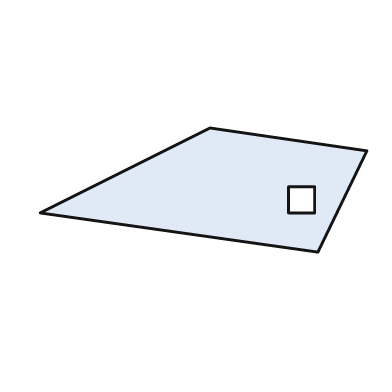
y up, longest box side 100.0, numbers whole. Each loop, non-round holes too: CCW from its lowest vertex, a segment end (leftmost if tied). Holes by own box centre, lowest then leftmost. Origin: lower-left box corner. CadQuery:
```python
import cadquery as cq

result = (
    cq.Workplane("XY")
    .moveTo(85.0, 0.0)
    .lineTo(100.0, 31.0)
    .lineTo(52.0, 38.0)
    .lineTo(0.0, 12.0)
    .close()
    .moveTo(76.0, 12.0)
    .lineTo(84.0, 12.0)
    .lineTo(84.0, 20.0)
    .lineTo(76.0, 20.0)
    .close()
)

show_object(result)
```